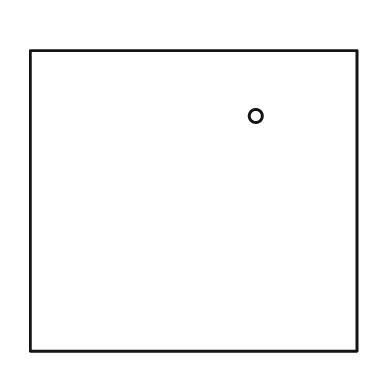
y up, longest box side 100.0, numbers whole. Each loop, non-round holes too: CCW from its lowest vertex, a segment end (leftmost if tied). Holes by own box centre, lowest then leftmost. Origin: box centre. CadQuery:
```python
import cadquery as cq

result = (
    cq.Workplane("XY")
    .moveTo(-50.0, -46.0)
    .lineTo(50.0, -46.0)
    .lineTo(50.0, 46.0)
    .lineTo(-50.0, 46.0)
    .close()
    .moveTo(19.0, 26.0)
    .circle(2.0)
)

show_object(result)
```